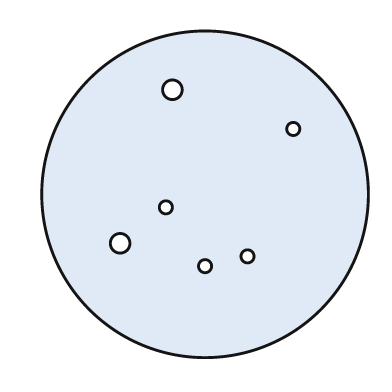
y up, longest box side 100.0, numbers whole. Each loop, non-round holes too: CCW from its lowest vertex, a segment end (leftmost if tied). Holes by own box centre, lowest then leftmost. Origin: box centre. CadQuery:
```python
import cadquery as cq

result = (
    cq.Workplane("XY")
    .moveTo(0.0, 0.0)
    .circle(50.0)
    .moveTo(0.0, -22.0)
    .circle(2.0)
    .moveTo(13.0, -19.0)
    .circle(2.0)
    .moveTo(-26.0, -15.0)
    .circle(3.0)
    .moveTo(-12.0, -4.0)
    .circle(2.0)
    .moveTo(27.0, 20.0)
    .circle(2.0)
    .moveTo(-10.0, 32.0)
    .circle(3.0)
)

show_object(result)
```